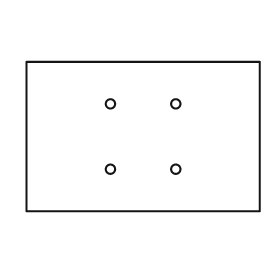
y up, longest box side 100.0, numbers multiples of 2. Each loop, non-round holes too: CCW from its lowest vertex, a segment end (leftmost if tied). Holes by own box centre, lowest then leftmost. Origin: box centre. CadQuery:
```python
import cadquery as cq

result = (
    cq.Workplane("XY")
    .moveTo(-50.0, -32.0)
    .lineTo(50.0, -32.0)
    .lineTo(50.0, 32.0)
    .lineTo(-50.0, 32.0)
    .close()
    .moveTo(-14.0, -14.0)
    .circle(2.0)
    .moveTo(14.0, -14.0)
    .circle(2.0)
    .moveTo(-14.0, 14.0)
    .circle(2.0)
    .moveTo(14.0, 14.0)
    .circle(2.0)
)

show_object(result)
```